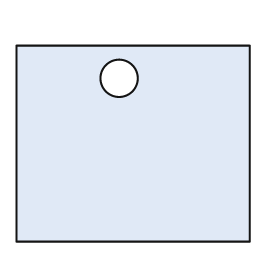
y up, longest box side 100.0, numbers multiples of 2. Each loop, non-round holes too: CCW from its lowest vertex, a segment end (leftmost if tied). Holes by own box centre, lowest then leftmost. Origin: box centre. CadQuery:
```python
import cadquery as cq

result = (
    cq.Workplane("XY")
    .moveTo(-50.0, -42.0)
    .lineTo(50.0, -42.0)
    .lineTo(50.0, 42.0)
    .lineTo(-50.0, 42.0)
    .close()
    .moveTo(-6.0, 28.0)
    .circle(8.0)
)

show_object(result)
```